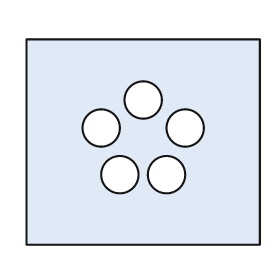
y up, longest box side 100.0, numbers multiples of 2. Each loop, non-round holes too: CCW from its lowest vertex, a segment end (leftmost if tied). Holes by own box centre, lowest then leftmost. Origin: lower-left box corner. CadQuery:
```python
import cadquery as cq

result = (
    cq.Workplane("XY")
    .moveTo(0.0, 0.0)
    .lineTo(100.0, 0.0)
    .lineTo(100.0, 88.0)
    .lineTo(0.0, 88.0)
    .close()
    .moveTo(40.0, 30.0)
    .circle(8.0)
    .moveTo(60.0, 30.0)
    .circle(8.0)
    .moveTo(32.0, 50.0)
    .circle(8.0)
    .moveTo(68.0, 50.0)
    .circle(8.0)
    .moveTo(50.0, 62.0)
    .circle(8.0)
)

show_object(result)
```